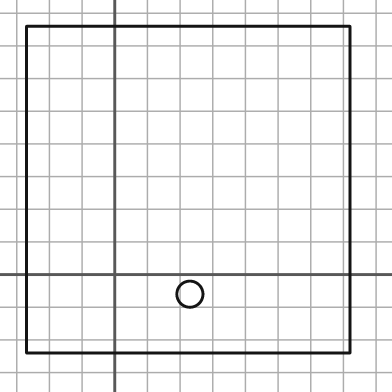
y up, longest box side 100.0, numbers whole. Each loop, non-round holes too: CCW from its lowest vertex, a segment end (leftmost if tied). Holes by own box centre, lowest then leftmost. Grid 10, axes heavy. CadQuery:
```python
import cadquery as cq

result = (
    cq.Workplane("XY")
    .moveTo(-27.0, -24.0)
    .lineTo(72.0, -24.0)
    .lineTo(72.0, 76.0)
    .lineTo(-27.0, 76.0)
    .close()
    .moveTo(23.0, -6.0)
    .circle(4.0)
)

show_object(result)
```